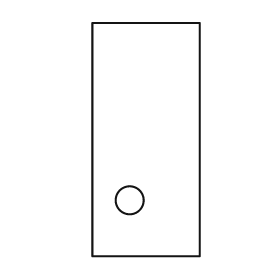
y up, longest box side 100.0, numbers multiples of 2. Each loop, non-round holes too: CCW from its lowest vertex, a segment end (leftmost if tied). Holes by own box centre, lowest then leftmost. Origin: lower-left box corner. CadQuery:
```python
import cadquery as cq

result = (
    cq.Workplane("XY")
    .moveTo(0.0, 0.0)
    .lineTo(46.0, 0.0)
    .lineTo(46.0, 100.0)
    .lineTo(0.0, 100.0)
    .close()
    .moveTo(16.0, 24.0)
    .circle(6.0)
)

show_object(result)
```